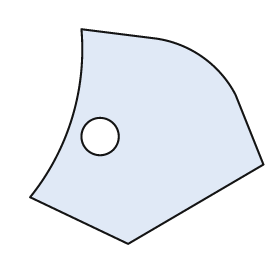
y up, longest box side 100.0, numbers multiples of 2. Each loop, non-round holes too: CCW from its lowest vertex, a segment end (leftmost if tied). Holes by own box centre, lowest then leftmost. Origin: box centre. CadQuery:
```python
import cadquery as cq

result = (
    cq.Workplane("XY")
    .moveTo(-8.0, -46.0)
    .lineTo(50.0, -12.0)
    .lineTo(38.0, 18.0)
    .threePointArc((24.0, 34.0), (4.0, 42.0))
    .lineTo(-28.0, 46.0)
    .threePointArc((-32.0, 8.0), (-50.0, -26.0))
    .close()
    .moveTo(-20.0, 0.0)
    .circle(8.0)
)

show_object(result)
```